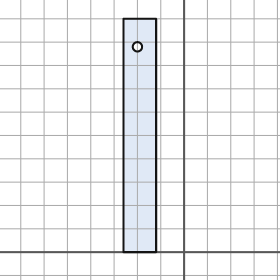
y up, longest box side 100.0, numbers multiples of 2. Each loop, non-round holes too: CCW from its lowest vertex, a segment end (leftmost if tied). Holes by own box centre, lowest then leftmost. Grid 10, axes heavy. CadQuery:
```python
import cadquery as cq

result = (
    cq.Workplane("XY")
    .moveTo(-26.0, 0.0)
    .lineTo(-12.0, 0.0)
    .lineTo(-12.0, 100.0)
    .lineTo(-26.0, 100.0)
    .close()
    .moveTo(-20.0, 88.0)
    .circle(2.0)
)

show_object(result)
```